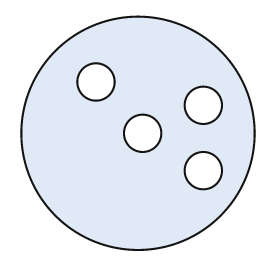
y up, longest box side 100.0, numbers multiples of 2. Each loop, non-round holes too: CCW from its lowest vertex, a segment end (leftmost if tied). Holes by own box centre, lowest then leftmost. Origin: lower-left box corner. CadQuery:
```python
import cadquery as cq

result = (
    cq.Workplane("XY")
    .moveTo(50.0, 50.0)
    .circle(50.0)
    .moveTo(78.0, 34.0)
    .circle(8.0)
    .moveTo(52.0, 50.0)
    .circle(8.0)
    .moveTo(78.0, 62.0)
    .circle(8.0)
    .moveTo(32.0, 72.0)
    .circle(8.0)
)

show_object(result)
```